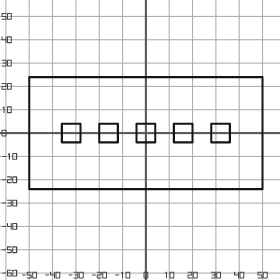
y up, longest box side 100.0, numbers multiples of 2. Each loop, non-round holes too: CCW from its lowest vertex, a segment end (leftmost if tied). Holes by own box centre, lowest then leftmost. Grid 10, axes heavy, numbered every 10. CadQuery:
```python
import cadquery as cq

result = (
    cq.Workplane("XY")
    .moveTo(-50.0, -24.0)
    .lineTo(50.0, -24.0)
    .lineTo(50.0, 24.0)
    .lineTo(-50.0, 24.0)
    .close()
    .moveTo(-36.0, -4.0)
    .lineTo(-28.0, -4.0)
    .lineTo(-28.0, 4.0)
    .lineTo(-36.0, 4.0)
    .close()
    .moveTo(-20.0, -4.0)
    .lineTo(-12.0, -4.0)
    .lineTo(-12.0, 4.0)
    .lineTo(-20.0, 4.0)
    .close()
    .moveTo(-4.0, -4.0)
    .lineTo(4.0, -4.0)
    .lineTo(4.0, 4.0)
    .lineTo(-4.0, 4.0)
    .close()
    .moveTo(12.0, -4.0)
    .lineTo(20.0, -4.0)
    .lineTo(20.0, 4.0)
    .lineTo(12.0, 4.0)
    .close()
    .moveTo(28.0, -4.0)
    .lineTo(36.0, -4.0)
    .lineTo(36.0, 4.0)
    .lineTo(28.0, 4.0)
    .close()
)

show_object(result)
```